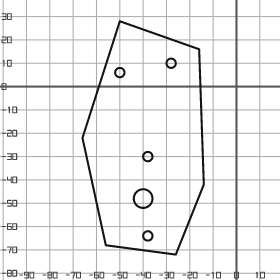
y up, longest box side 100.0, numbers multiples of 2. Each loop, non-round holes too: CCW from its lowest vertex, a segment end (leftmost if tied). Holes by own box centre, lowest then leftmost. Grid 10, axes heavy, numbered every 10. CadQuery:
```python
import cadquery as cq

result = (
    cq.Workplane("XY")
    .moveTo(-26.0, -72.0)
    .lineTo(-14.0, -42.0)
    .lineTo(-16.0, 16.0)
    .lineTo(-50.0, 28.0)
    .lineTo(-66.0, -22.0)
    .lineTo(-56.0, -68.0)
    .close()
    .moveTo(-38.0, -64.0)
    .circle(2.0)
    .moveTo(-40.0, -48.0)
    .circle(4.0)
    .moveTo(-38.0, -30.0)
    .circle(2.0)
    .moveTo(-50.0, 6.0)
    .circle(2.0)
    .moveTo(-28.0, 10.0)
    .circle(2.0)
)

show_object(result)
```